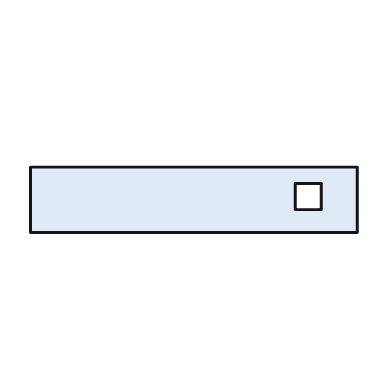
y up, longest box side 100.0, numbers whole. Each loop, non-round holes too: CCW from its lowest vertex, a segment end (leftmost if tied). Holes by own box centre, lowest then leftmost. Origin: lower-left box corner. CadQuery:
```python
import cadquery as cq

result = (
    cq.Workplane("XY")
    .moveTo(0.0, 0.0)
    .lineTo(100.0, 0.0)
    .lineTo(100.0, 20.0)
    .lineTo(0.0, 20.0)
    .close()
    .moveTo(81.0, 7.0)
    .lineTo(89.0, 7.0)
    .lineTo(89.0, 15.0)
    .lineTo(81.0, 15.0)
    .close()
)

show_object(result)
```